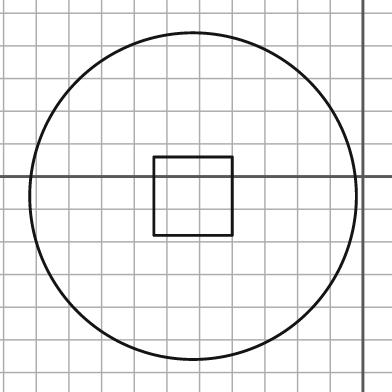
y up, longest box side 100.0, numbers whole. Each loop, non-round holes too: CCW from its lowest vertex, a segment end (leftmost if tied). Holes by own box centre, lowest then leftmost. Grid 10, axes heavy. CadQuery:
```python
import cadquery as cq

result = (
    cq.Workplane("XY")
    .moveTo(-52.0, -6.0)
    .circle(50.0)
    .moveTo(-64.0, -18.0)
    .lineTo(-40.0, -18.0)
    .lineTo(-40.0, 6.0)
    .lineTo(-64.0, 6.0)
    .close()
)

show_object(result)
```